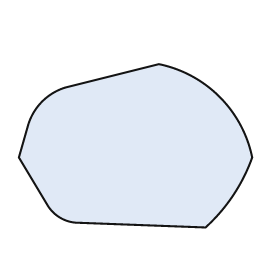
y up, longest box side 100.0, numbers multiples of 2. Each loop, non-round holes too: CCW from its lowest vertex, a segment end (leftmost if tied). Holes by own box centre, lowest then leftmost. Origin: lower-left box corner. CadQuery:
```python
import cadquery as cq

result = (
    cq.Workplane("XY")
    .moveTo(80.0, 0.0)
    .threePointArc((92.0, 14.0), (100.0, 30.0))
    .threePointArc((86.0, 56.0), (60.0, 70.0))
    .lineTo(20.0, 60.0)
    .threePointArc((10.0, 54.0), (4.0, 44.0))
    .lineTo(0.0, 30.0)
    .lineTo(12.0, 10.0)
    .threePointArc((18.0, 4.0), (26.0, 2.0))
    .close()
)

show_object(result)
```